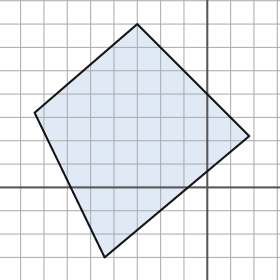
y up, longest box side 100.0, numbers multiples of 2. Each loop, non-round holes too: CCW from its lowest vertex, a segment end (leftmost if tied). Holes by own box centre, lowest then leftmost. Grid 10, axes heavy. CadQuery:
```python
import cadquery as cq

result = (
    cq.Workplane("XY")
    .moveTo(-44.0, -30.0)
    .lineTo(18.0, 22.0)
    .lineTo(-30.0, 70.0)
    .lineTo(-74.0, 32.0)
    .close()
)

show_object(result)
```